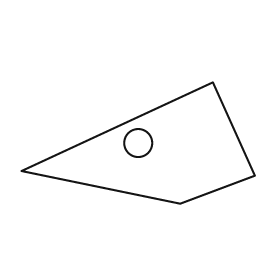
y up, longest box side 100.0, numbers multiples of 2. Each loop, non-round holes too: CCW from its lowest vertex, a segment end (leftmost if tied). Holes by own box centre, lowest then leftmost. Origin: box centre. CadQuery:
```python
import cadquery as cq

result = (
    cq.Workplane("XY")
    .moveTo(18.0, -26.0)
    .lineTo(50.0, -14.0)
    .lineTo(32.0, 26.0)
    .lineTo(-50.0, -12.0)
    .close()
    .moveTo(0.0, 0.0)
    .circle(6.0)
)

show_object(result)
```